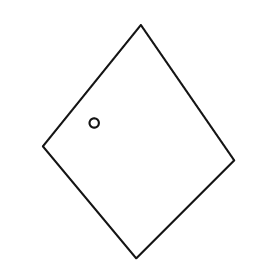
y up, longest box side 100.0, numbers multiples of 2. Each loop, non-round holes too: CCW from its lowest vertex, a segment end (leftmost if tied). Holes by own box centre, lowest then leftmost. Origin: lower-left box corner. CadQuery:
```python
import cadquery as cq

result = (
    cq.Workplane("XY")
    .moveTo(40.0, 0.0)
    .lineTo(82.0, 42.0)
    .lineTo(42.0, 100.0)
    .lineTo(0.0, 48.0)
    .close()
    .moveTo(22.0, 58.0)
    .circle(2.0)
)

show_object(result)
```